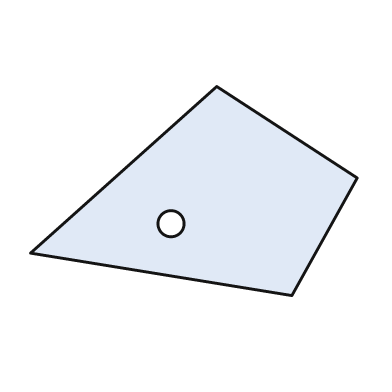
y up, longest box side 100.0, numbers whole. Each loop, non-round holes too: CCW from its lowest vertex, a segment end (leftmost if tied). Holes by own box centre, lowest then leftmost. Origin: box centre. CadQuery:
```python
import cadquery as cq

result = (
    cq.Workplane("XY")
    .moveTo(30.0, -32.0)
    .lineTo(50.0, 4.0)
    .lineTo(7.0, 32.0)
    .lineTo(-50.0, -19.0)
    .close()
    .moveTo(-7.0, -10.0)
    .circle(4.0)
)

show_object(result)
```